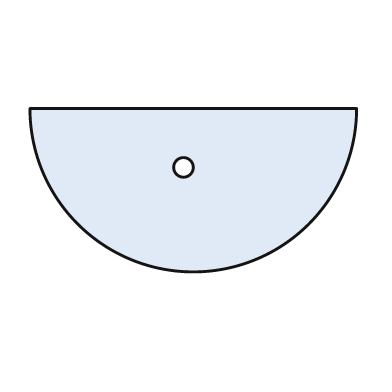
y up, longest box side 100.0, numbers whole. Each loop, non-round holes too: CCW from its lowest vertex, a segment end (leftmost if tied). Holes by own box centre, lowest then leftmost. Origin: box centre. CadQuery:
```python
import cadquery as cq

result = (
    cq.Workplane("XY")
    .moveTo(-50.0, 25.0)
    .threePointArc((0.0, -25.0), (50.0, 25.0))
    .close()
    .moveTo(-3.0, 7.0)
    .circle(3.0)
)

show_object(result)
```